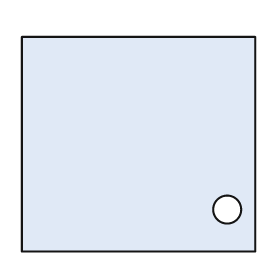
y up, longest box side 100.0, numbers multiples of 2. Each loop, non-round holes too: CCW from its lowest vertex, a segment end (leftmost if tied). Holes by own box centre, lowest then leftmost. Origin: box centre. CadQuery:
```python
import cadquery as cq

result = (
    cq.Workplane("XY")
    .moveTo(-50.0, -46.0)
    .lineTo(50.0, -46.0)
    .lineTo(50.0, 46.0)
    .lineTo(-50.0, 46.0)
    .close()
    .moveTo(38.0, -28.0)
    .circle(6.0)
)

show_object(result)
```